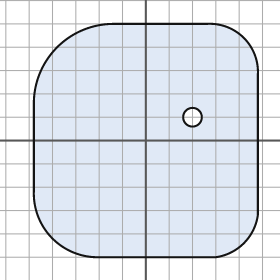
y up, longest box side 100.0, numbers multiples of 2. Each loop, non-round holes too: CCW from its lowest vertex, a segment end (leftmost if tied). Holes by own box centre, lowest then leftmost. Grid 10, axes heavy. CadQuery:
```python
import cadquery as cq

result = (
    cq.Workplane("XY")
    .moveTo(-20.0, -50.0)
    .lineTo(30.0, -50.0)
    .threePointArc((42.0, -44.0), (48.0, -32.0))
    .lineTo(48.0, 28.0)
    .threePointArc((42.0, 44.0), (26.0, 50.0))
    .lineTo(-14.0, 50.0)
    .threePointArc((-38.0, 40.0), (-48.0, 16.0))
    .lineTo(-48.0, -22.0)
    .threePointArc((-40.0, -42.0), (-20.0, -50.0))
    .close()
    .moveTo(20.0, 10.0)
    .circle(4.0)
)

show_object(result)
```